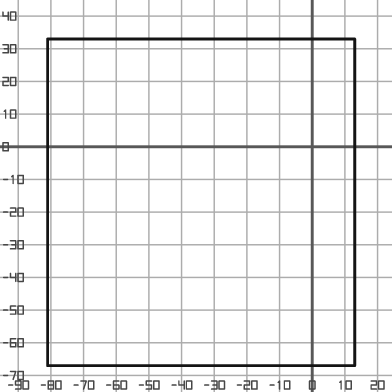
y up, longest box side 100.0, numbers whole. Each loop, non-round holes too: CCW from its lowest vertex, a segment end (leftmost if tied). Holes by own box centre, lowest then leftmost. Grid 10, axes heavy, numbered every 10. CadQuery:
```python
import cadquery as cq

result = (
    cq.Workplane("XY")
    .moveTo(-81.0, -67.0)
    .lineTo(13.0, -67.0)
    .lineTo(13.0, 33.0)
    .lineTo(-81.0, 33.0)
    .close()
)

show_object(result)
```